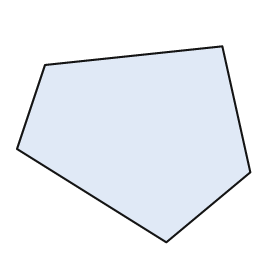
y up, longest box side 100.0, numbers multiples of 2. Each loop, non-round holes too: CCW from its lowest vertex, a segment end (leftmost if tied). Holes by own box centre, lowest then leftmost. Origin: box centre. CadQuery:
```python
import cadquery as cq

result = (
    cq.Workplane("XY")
    .moveTo(14.0, -42.0)
    .lineTo(50.0, -12.0)
    .lineTo(38.0, 42.0)
    .lineTo(-38.0, 34.0)
    .lineTo(-50.0, -2.0)
    .close()
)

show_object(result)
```